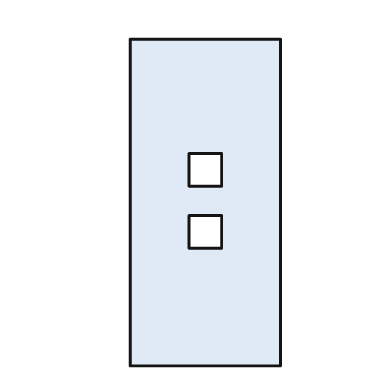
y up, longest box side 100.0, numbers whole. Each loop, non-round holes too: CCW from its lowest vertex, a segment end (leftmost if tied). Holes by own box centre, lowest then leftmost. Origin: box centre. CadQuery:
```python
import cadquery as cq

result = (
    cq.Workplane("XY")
    .moveTo(-23.0, -50.0)
    .lineTo(23.0, -50.0)
    .lineTo(23.0, 50.0)
    .lineTo(-23.0, 50.0)
    .close()
    .moveTo(-5.0, -14.0)
    .lineTo(5.0, -14.0)
    .lineTo(5.0, -4.0)
    .lineTo(-5.0, -4.0)
    .close()
    .moveTo(-5.0, 5.0)
    .lineTo(5.0, 5.0)
    .lineTo(5.0, 15.0)
    .lineTo(-5.0, 15.0)
    .close()
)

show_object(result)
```